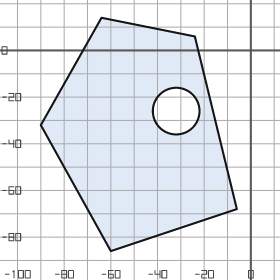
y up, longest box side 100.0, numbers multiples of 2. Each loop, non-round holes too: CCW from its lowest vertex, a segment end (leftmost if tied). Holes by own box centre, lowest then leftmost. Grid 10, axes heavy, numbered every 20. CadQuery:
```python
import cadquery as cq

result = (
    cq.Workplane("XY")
    .moveTo(-60.0, -86.0)
    .lineTo(-6.0, -68.0)
    .lineTo(-24.0, 6.0)
    .lineTo(-64.0, 14.0)
    .lineTo(-90.0, -32.0)
    .close()
    .moveTo(-32.0, -26.0)
    .circle(10.0)
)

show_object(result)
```